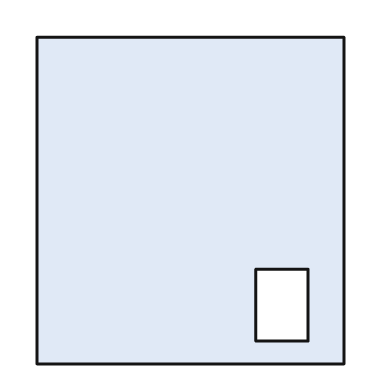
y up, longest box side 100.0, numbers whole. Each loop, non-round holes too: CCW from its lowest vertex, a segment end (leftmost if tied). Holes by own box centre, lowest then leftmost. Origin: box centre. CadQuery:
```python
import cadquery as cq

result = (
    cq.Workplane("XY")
    .moveTo(-47.0, -50.0)
    .lineTo(47.0, -50.0)
    .lineTo(47.0, 50.0)
    .lineTo(-47.0, 50.0)
    .close()
    .moveTo(20.0, -43.0)
    .lineTo(36.0, -43.0)
    .lineTo(36.0, -21.0)
    .lineTo(20.0, -21.0)
    .close()
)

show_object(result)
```